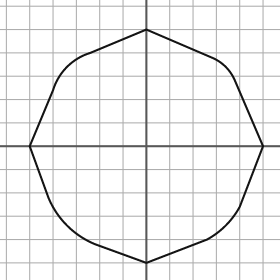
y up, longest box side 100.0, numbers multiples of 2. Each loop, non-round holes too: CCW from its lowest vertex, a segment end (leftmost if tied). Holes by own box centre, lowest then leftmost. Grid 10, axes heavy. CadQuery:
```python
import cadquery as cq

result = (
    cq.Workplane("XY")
    .moveTo(0.0, -50.0)
    .lineTo(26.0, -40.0)
    .threePointArc((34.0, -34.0), (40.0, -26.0))
    .lineTo(50.0, 0.0)
    .lineTo(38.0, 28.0)
    .threePointArc((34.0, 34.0), (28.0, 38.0))
    .lineTo(0.0, 50.0)
    .lineTo(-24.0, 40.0)
    .threePointArc((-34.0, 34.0), (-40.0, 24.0))
    .lineTo(-50.0, 0.0)
    .lineTo(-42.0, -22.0)
    .threePointArc((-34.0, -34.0), (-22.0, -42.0))
    .close()
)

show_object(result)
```